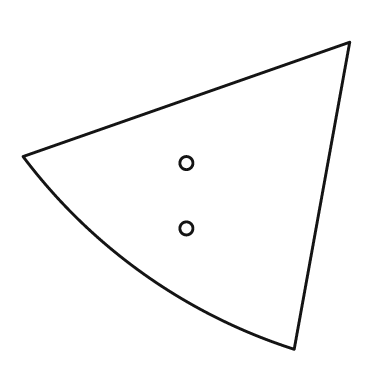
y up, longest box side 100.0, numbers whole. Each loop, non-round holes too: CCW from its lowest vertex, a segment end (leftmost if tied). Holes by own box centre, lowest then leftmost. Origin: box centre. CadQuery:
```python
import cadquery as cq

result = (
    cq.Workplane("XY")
    .moveTo(33.0, -47.0)
    .lineTo(50.0, 47.0)
    .lineTo(-50.0, 12.0)
    .threePointArc((-13.0, -24.0), (33.0, -47.0))
    .close()
    .moveTo(0.0, -10.0)
    .circle(2.0)
    .moveTo(0.0, 10.0)
    .circle(2.0)
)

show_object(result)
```